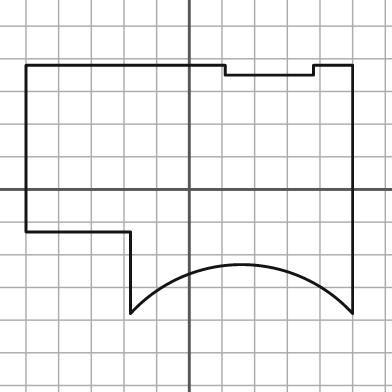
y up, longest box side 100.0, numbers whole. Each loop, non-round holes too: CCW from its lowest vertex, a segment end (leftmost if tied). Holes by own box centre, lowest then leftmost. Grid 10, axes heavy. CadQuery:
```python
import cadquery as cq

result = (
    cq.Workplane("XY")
    .moveTo(-18.0, -38.0)
    .threePointArc((16.0, -23.0), (50.0, -38.0))
    .lineTo(50.0, 38.0)
    .lineTo(38.0, 38.0)
    .lineTo(38.0, 35.0)
    .lineTo(11.0, 35.0)
    .lineTo(11.0, 38.0)
    .lineTo(-50.0, 38.0)
    .lineTo(-50.0, -13.0)
    .lineTo(-18.0, -13.0)
    .close()
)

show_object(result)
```